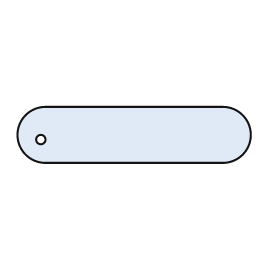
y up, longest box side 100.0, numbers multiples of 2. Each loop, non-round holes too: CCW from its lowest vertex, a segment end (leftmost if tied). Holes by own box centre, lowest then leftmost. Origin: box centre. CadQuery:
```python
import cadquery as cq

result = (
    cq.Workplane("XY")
    .moveTo(-38.0, -12.0)
    .lineTo(38.0, -12.0)
    .threePointArc((50.0, 0.0), (38.0, 12.0))
    .lineTo(-38.0, 12.0)
    .threePointArc((-50.0, 0.0), (-38.0, -12.0))
    .close()
    .moveTo(-40.0, -2.0)
    .circle(2.0)
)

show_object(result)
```